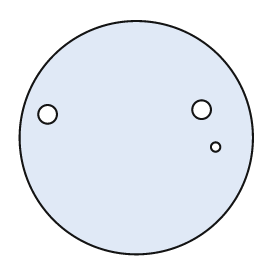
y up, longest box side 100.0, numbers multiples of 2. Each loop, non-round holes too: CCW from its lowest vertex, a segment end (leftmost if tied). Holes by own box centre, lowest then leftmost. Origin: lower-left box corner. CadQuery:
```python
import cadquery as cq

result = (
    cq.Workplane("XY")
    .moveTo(50.0, 50.0)
    .circle(50.0)
    .moveTo(84.0, 46.0)
    .circle(2.0)
    .moveTo(12.0, 60.0)
    .circle(4.0)
    .moveTo(78.0, 62.0)
    .circle(4.0)
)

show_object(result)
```